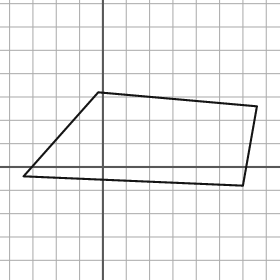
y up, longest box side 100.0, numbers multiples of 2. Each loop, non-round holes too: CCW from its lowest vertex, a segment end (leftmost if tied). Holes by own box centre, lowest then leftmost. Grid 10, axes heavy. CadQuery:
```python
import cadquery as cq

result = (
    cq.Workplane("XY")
    .moveTo(60.0, -8.0)
    .lineTo(66.0, 26.0)
    .lineTo(-2.0, 32.0)
    .lineTo(-34.0, -4.0)
    .close()
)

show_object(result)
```